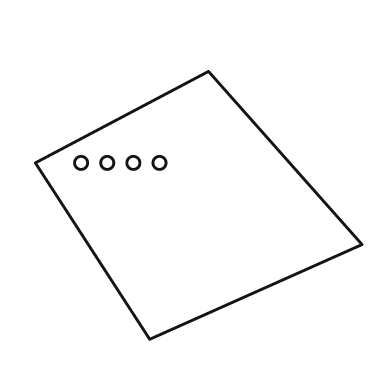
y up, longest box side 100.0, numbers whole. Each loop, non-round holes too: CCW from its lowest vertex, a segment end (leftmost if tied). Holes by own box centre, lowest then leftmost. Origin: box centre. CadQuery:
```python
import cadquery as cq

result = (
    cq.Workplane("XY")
    .moveTo(-15.0, -41.0)
    .lineTo(50.0, -12.0)
    .lineTo(3.0, 41.0)
    .lineTo(-50.0, 13.0)
    .close()
    .moveTo(-36.0, 13.0)
    .circle(2.0)
    .moveTo(-28.0, 13.0)
    .circle(2.0)
    .moveTo(-20.0, 13.0)
    .circle(2.0)
    .moveTo(-12.0, 13.0)
    .circle(2.0)
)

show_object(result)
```